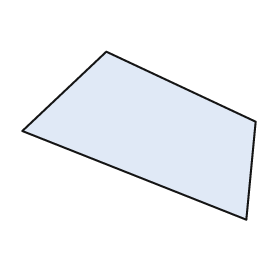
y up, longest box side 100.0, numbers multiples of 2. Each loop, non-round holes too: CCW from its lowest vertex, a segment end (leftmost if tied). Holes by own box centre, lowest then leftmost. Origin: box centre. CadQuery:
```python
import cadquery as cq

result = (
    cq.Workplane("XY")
    .moveTo(46.0, -36.0)
    .lineTo(50.0, 6.0)
    .lineTo(-14.0, 36.0)
    .lineTo(-50.0, 2.0)
    .close()
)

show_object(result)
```